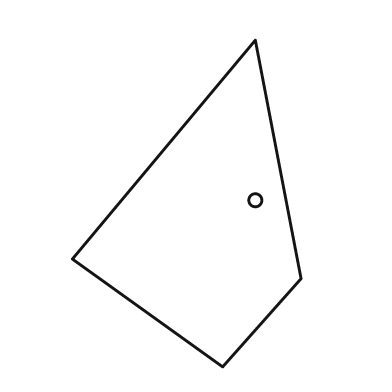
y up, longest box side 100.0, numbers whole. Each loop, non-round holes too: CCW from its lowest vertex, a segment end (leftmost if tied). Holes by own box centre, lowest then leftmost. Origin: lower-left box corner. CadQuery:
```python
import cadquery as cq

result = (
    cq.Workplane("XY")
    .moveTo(46.0, 0.0)
    .lineTo(70.0, 27.0)
    .lineTo(56.0, 100.0)
    .lineTo(0.0, 33.0)
    .close()
    .moveTo(56.0, 51.0)
    .circle(2.0)
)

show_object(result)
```